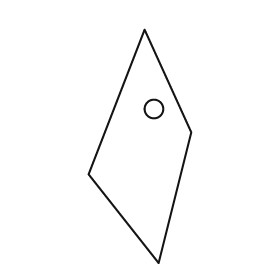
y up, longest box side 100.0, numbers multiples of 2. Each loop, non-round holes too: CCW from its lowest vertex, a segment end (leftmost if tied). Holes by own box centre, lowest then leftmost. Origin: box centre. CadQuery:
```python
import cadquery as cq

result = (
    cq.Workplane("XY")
    .moveTo(8.0, -50.0)
    .lineTo(22.0, 6.0)
    .lineTo(2.0, 50.0)
    .lineTo(-22.0, -12.0)
    .close()
    .moveTo(6.0, 16.0)
    .circle(4.0)
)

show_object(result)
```